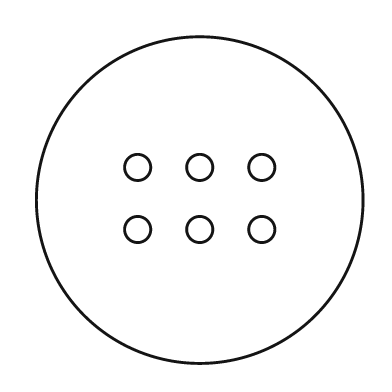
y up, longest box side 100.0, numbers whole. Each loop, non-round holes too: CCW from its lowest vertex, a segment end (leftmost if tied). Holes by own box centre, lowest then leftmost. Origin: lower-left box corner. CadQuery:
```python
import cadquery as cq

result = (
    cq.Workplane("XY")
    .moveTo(50.0, 50.0)
    .circle(50.0)
    .moveTo(31.0, 41.0)
    .circle(4.0)
    .moveTo(50.0, 41.0)
    .circle(4.0)
    .moveTo(69.0, 41.0)
    .circle(4.0)
    .moveTo(31.0, 60.0)
    .circle(4.0)
    .moveTo(50.0, 60.0)
    .circle(4.0)
    .moveTo(69.0, 60.0)
    .circle(4.0)
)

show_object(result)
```